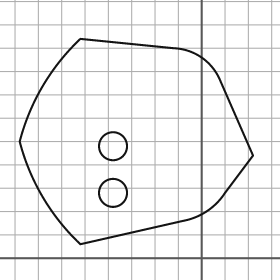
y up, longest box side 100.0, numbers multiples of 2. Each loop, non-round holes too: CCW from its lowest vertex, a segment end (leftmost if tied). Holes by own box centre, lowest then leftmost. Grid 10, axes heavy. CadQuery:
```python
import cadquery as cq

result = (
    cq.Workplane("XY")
    .moveTo(-52.0, 6.0)
    .lineTo(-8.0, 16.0)
    .threePointArc((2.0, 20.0), (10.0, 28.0))
    .lineTo(22.0, 44.0)
    .lineTo(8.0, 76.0)
    .threePointArc((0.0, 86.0), (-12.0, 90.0))
    .lineTo(-52.0, 94.0)
    .threePointArc((-68.0, 74.0), (-78.0, 50.0))
    .threePointArc((-68.0, 26.0), (-52.0, 6.0))
    .close()
    .moveTo(-38.0, 28.0)
    .circle(6.0)
    .moveTo(-38.0, 48.0)
    .circle(6.0)
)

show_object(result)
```